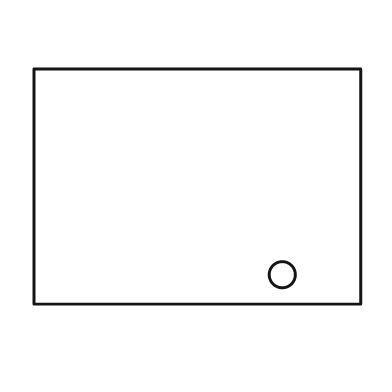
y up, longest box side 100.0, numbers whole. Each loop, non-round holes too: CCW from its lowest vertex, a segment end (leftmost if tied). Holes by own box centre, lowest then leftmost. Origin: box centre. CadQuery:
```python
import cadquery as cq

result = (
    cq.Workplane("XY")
    .moveTo(-50.0, -36.0)
    .lineTo(50.0, -36.0)
    .lineTo(50.0, 36.0)
    .lineTo(-50.0, 36.0)
    .close()
    .moveTo(26.0, -27.0)
    .circle(4.0)
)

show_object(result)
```